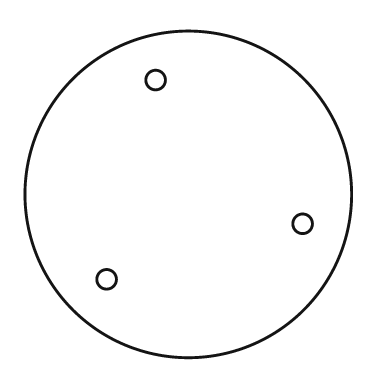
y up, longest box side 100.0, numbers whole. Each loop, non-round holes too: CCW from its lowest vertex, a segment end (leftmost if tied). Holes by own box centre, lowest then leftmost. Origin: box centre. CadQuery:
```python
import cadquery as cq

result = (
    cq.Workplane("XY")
    .moveTo(0.0, 0.0)
    .circle(50.0)
    .moveTo(-25.0, -26.0)
    .circle(3.0)
    .moveTo(35.0, -9.0)
    .circle(3.0)
    .moveTo(-10.0, 35.0)
    .circle(3.0)
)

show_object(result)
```